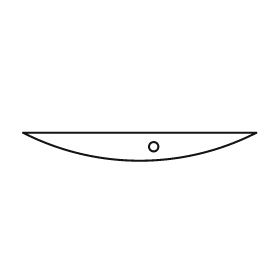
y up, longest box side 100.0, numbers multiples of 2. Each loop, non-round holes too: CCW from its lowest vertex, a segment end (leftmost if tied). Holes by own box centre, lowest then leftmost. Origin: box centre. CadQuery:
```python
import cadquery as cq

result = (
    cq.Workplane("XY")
    .moveTo(-50.0, 6.0)
    .threePointArc((0.0, -6.0), (50.0, 6.0))
    .close()
    .moveTo(6.0, 0.0)
    .circle(2.0)
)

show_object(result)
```